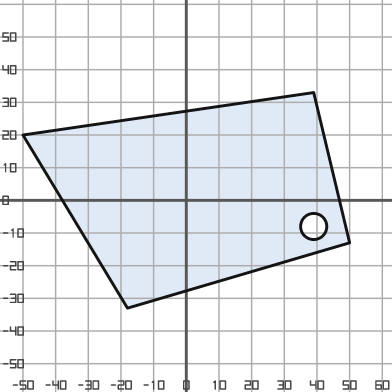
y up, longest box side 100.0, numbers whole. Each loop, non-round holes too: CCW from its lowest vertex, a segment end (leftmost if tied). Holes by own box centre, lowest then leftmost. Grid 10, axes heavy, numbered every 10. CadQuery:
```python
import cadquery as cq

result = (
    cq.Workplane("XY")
    .moveTo(-18.0, -33.0)
    .lineTo(50.0, -13.0)
    .lineTo(39.0, 33.0)
    .lineTo(-50.0, 20.0)
    .close()
    .moveTo(39.0, -8.0)
    .circle(4.0)
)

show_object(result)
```